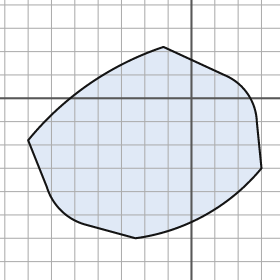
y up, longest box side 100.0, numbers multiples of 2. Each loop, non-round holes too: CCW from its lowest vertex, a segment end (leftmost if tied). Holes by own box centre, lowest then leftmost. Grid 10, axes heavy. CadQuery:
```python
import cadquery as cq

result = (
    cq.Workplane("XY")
    .moveTo(-24.0, -60.0)
    .threePointArc((6.0, -50.0), (30.0, -30.0))
    .lineTo(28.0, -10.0)
    .threePointArc((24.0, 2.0), (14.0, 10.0))
    .lineTo(-12.0, 22.0)
    .threePointArc((-44.0, 6.0), (-70.0, -18.0))
    .lineTo(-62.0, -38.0)
    .threePointArc((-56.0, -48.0), (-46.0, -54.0))
    .close()
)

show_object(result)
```